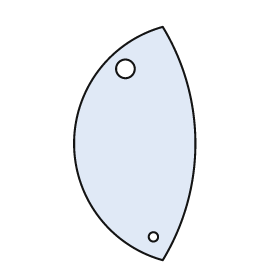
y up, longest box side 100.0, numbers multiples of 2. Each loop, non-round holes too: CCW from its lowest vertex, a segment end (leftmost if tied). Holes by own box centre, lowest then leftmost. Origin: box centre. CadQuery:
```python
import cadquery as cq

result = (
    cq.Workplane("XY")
    .moveTo(12.0, -50.0)
    .threePointArc((26.0, 0.0), (12.0, 50.0))
    .threePointArc((-26.0, 0.0), (12.0, -50.0))
    .close()
    .moveTo(8.0, -40.0)
    .circle(2.0)
    .moveTo(-4.0, 32.0)
    .circle(4.0)
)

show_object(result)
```